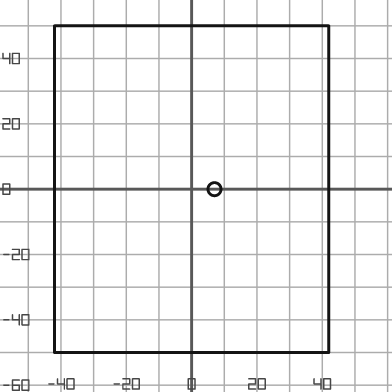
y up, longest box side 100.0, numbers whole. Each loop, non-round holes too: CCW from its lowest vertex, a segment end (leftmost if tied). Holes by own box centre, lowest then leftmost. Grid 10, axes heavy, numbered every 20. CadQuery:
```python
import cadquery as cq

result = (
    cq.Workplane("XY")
    .moveTo(-42.0, -50.0)
    .lineTo(42.0, -50.0)
    .lineTo(42.0, 50.0)
    .lineTo(-42.0, 50.0)
    .close()
    .moveTo(7.0, 0.0)
    .circle(2.0)
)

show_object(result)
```